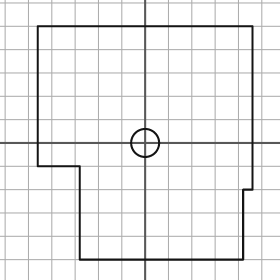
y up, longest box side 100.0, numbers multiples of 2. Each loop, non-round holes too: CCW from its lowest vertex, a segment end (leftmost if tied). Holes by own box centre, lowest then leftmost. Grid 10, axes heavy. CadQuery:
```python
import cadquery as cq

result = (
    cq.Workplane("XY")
    .moveTo(-28.0, -50.0)
    .lineTo(42.0, -50.0)
    .lineTo(42.0, -20.0)
    .lineTo(46.0, -20.0)
    .lineTo(46.0, 50.0)
    .lineTo(-46.0, 50.0)
    .lineTo(-46.0, -10.0)
    .lineTo(-28.0, -10.0)
    .close()
    .moveTo(0.0, 0.0)
    .circle(6.0)
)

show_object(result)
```